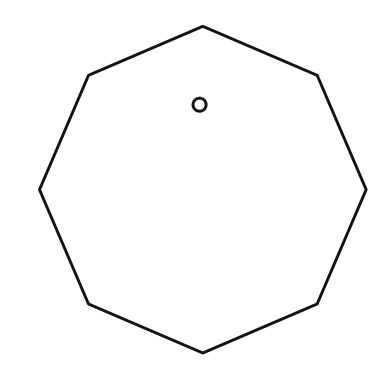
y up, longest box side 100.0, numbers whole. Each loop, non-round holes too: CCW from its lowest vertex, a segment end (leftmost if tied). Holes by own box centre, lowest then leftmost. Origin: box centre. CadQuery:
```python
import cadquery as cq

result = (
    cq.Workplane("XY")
    .moveTo(0.0, -50.0)
    .lineTo(35.0, -35.0)
    .lineTo(50.0, 0.0)
    .lineTo(35.0, 35.0)
    .lineTo(0.0, 50.0)
    .lineTo(-35.0, 35.0)
    .lineTo(-50.0, 0.0)
    .lineTo(-35.0, -35.0)
    .close()
    .moveTo(-1.0, 26.0)
    .circle(2.0)
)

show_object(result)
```